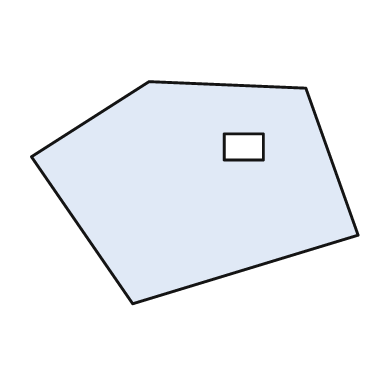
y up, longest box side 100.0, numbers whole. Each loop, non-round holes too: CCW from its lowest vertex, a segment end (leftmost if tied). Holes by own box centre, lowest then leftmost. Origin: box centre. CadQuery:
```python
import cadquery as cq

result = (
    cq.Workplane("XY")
    .moveTo(-19.0, -34.0)
    .lineTo(50.0, -13.0)
    .lineTo(34.0, 32.0)
    .lineTo(-14.0, 34.0)
    .lineTo(-50.0, 11.0)
    .close()
    .moveTo(9.0, 10.0)
    .lineTo(21.0, 10.0)
    .lineTo(21.0, 18.0)
    .lineTo(9.0, 18.0)
    .close()
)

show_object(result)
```